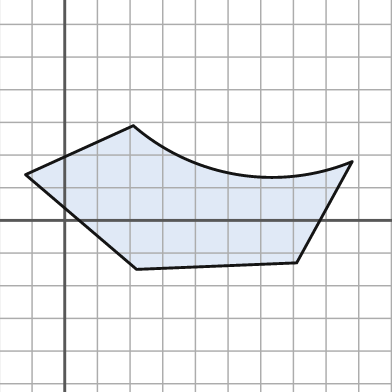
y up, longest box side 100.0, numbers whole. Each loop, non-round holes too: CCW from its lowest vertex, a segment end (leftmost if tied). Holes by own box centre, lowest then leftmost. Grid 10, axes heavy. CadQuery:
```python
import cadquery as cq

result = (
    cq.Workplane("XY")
    .moveTo(22.0, -15.0)
    .lineTo(71.0, -13.0)
    .lineTo(88.0, 18.0)
    .threePointArc((53.0, 14.0), (21.0, 29.0))
    .lineTo(-12.0, 14.0)
    .close()
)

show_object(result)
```